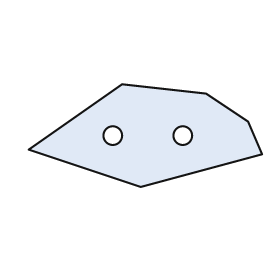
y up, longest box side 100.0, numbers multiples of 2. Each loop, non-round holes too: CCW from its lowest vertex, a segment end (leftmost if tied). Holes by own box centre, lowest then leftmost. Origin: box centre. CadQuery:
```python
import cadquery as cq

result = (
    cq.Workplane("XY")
    .moveTo(-2.0, -22.0)
    .lineTo(50.0, -8.0)
    .lineTo(44.0, 6.0)
    .lineTo(26.0, 18.0)
    .lineTo(-10.0, 22.0)
    .lineTo(-50.0, -6.0)
    .close()
    .moveTo(-14.0, 0.0)
    .circle(4.0)
    .moveTo(16.0, 0.0)
    .circle(4.0)
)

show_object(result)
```